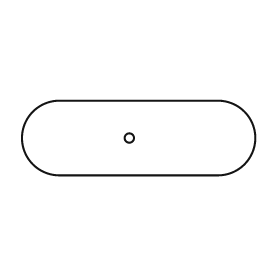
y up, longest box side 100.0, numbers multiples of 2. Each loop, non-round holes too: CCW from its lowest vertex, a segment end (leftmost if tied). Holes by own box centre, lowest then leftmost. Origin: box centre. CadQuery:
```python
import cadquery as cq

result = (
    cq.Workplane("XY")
    .moveTo(-34.0, -16.0)
    .lineTo(34.0, -16.0)
    .threePointArc((50.0, 0.0), (34.0, 16.0))
    .lineTo(-34.0, 16.0)
    .threePointArc((-50.0, 0.0), (-34.0, -16.0))
    .close()
    .moveTo(-4.0, 0.0)
    .circle(2.0)
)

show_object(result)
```